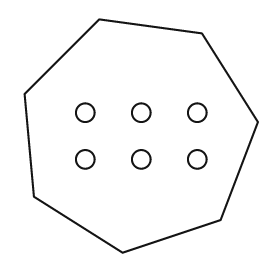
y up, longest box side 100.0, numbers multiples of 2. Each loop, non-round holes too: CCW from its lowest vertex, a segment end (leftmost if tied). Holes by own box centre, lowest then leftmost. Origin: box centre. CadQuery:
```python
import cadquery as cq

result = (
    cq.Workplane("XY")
    .moveTo(-8.0, -50.0)
    .lineTo(34.0, -36.0)
    .lineTo(50.0, 6.0)
    .lineTo(26.0, 44.0)
    .lineTo(-18.0, 50.0)
    .lineTo(-50.0, 18.0)
    .lineTo(-46.0, -26.0)
    .close()
    .moveTo(-24.0, -10.0)
    .circle(4.0)
    .moveTo(0.0, -10.0)
    .circle(4.0)
    .moveTo(24.0, -10.0)
    .circle(4.0)
    .moveTo(-24.0, 10.0)
    .circle(4.0)
    .moveTo(0.0, 10.0)
    .circle(4.0)
    .moveTo(24.0, 10.0)
    .circle(4.0)
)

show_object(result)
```